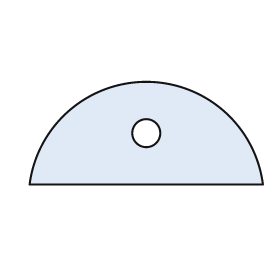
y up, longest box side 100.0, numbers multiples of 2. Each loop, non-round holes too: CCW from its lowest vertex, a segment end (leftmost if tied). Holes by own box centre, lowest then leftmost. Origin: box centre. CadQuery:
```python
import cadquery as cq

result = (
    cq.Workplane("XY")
    .moveTo(-50.0, -22.0)
    .lineTo(50.0, -22.0)
    .threePointArc((0.0, 22.0), (-50.0, -22.0))
    .close()
    .moveTo(0.0, 0.0)
    .circle(6.0)
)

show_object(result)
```